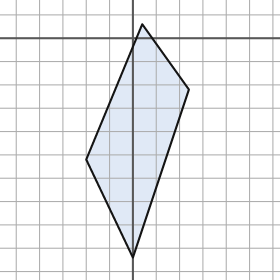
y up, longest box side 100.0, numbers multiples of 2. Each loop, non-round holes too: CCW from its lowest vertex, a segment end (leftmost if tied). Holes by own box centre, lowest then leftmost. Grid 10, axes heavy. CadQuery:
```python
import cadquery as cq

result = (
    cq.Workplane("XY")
    .moveTo(0.0, -94.0)
    .lineTo(24.0, -22.0)
    .lineTo(4.0, 6.0)
    .lineTo(-20.0, -52.0)
    .close()
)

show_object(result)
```